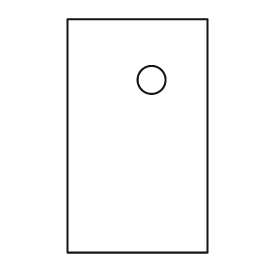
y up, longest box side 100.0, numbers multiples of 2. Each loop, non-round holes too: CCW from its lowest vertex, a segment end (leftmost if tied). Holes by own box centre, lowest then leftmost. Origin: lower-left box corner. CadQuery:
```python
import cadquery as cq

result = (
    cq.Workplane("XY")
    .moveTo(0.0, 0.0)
    .lineTo(60.0, 0.0)
    .lineTo(60.0, 100.0)
    .lineTo(0.0, 100.0)
    .close()
    .moveTo(36.0, 74.0)
    .circle(6.0)
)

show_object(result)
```